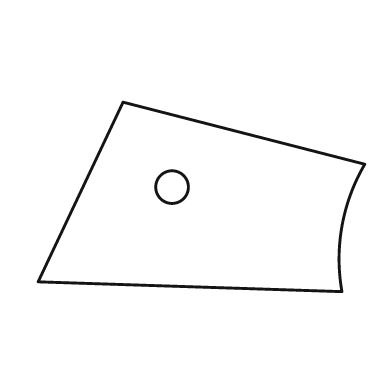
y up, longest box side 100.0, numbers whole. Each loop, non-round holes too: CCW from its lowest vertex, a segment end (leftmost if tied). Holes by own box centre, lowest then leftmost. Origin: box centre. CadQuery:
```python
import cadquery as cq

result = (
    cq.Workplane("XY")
    .moveTo(43.0, -29.0)
    .threePointArc((43.0, -9.0), (50.0, 10.0))
    .lineTo(-24.0, 29.0)
    .lineTo(-50.0, -26.0)
    .close()
    .moveTo(-9.0, 3.0)
    .circle(5.0)
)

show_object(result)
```